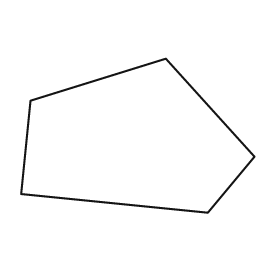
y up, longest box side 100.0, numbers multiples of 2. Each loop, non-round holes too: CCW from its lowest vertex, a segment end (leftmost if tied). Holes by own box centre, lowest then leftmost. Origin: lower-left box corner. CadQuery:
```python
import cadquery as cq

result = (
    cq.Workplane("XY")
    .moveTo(80.0, 0.0)
    .lineTo(100.0, 24.0)
    .lineTo(62.0, 66.0)
    .lineTo(4.0, 48.0)
    .lineTo(0.0, 8.0)
    .close()
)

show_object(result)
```